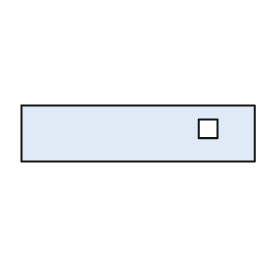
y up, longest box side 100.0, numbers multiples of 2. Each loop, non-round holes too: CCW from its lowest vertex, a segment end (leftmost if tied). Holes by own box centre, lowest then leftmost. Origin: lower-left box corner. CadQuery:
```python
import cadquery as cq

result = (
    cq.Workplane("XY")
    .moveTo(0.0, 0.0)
    .lineTo(100.0, 0.0)
    .lineTo(100.0, 24.0)
    .lineTo(0.0, 24.0)
    .close()
    .moveTo(76.0, 10.0)
    .lineTo(84.0, 10.0)
    .lineTo(84.0, 18.0)
    .lineTo(76.0, 18.0)
    .close()
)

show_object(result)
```